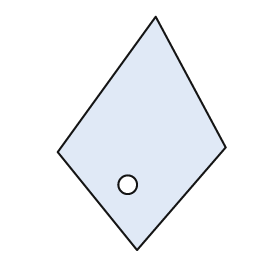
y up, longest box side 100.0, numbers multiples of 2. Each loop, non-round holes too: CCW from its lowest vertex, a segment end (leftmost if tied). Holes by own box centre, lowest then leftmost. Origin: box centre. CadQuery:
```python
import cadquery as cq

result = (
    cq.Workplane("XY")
    .moveTo(-2.0, -50.0)
    .lineTo(36.0, -6.0)
    .lineTo(6.0, 50.0)
    .lineTo(-36.0, -8.0)
    .close()
    .moveTo(-6.0, -22.0)
    .circle(4.0)
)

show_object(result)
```